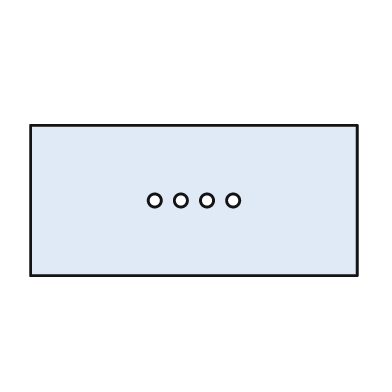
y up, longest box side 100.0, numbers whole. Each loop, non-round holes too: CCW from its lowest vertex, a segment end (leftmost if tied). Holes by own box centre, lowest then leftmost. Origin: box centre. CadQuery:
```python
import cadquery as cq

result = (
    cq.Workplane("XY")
    .moveTo(-50.0, -23.0)
    .lineTo(50.0, -23.0)
    .lineTo(50.0, 23.0)
    .lineTo(-50.0, 23.0)
    .close()
    .moveTo(-12.0, 0.0)
    .circle(2.0)
    .moveTo(-4.0, 0.0)
    .circle(2.0)
    .moveTo(4.0, 0.0)
    .circle(2.0)
    .moveTo(12.0, 0.0)
    .circle(2.0)
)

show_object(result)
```